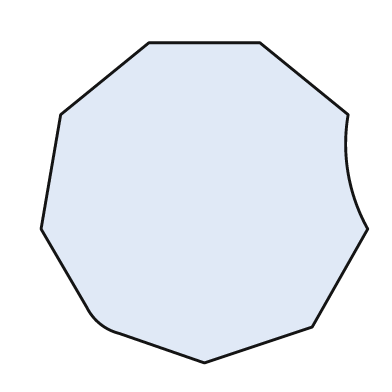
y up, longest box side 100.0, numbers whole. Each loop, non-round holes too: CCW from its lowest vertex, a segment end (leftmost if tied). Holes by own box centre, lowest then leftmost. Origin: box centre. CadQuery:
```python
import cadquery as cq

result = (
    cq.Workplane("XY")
    .moveTo(0.0, -49.0)
    .lineTo(33.0, -38.0)
    .lineTo(50.0, -8.0)
    .threePointArc((44.0, 9.0), (44.0, 27.0))
    .lineTo(17.0, 49.0)
    .lineTo(-17.0, 49.0)
    .lineTo(-44.0, 27.0)
    .lineTo(-50.0, -8.0)
    .lineTo(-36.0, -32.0)
    .threePointArc((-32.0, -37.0), (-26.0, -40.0))
    .close()
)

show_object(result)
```